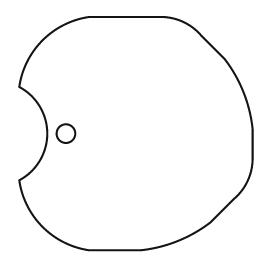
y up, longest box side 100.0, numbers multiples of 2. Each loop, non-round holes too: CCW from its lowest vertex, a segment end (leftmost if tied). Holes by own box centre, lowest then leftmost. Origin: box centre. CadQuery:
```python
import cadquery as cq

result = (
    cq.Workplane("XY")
    .moveTo(-20.0, -50.0)
    .lineTo(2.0, -50.0)
    .threePointArc((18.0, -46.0), (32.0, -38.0))
    .lineTo(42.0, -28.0)
    .threePointArc((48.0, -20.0), (50.0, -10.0))
    .lineTo(50.0, 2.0)
    .threePointArc((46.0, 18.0), (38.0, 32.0))
    .lineTo(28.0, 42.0)
    .threePointArc((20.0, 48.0), (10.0, 50.0))
    .lineTo(-20.0, 50.0)
    .threePointArc((-40.0, 40.0), (-50.0, 20.0))
    .threePointArc((-38.0, 0.0), (-50.0, -20.0))
    .threePointArc((-40.0, -40.0), (-20.0, -50.0))
    .close()
    .moveTo(-30.0, 0.0)
    .circle(4.0)
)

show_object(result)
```